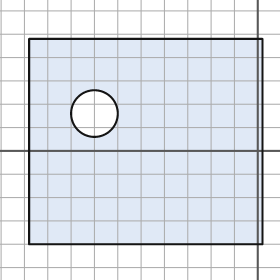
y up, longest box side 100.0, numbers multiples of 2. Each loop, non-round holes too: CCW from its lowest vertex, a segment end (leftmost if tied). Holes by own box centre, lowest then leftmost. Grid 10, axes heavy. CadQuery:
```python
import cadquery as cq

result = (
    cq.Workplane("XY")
    .moveTo(-98.0, -40.0)
    .lineTo(2.0, -40.0)
    .lineTo(2.0, 48.0)
    .lineTo(-98.0, 48.0)
    .close()
    .moveTo(-70.0, 16.0)
    .circle(10.0)
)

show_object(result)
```